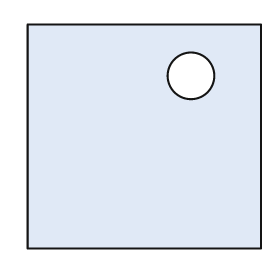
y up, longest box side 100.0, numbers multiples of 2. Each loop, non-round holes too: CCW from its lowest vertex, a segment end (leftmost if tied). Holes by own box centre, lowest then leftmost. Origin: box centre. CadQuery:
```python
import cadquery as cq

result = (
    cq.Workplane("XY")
    .moveTo(-50.0, -48.0)
    .lineTo(50.0, -48.0)
    .lineTo(50.0, 48.0)
    .lineTo(-50.0, 48.0)
    .close()
    .moveTo(20.0, 26.0)
    .circle(10.0)
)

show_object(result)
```